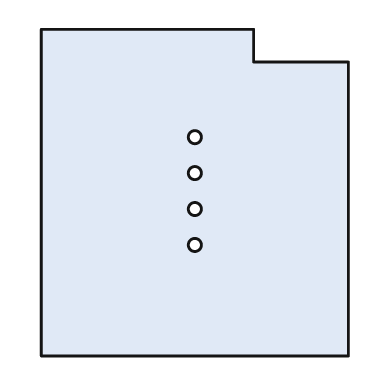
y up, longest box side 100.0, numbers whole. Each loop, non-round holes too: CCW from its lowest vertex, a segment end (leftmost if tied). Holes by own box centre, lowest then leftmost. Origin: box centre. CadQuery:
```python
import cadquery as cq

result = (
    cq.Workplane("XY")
    .moveTo(-47.0, -50.0)
    .lineTo(47.0, -50.0)
    .lineTo(47.0, 40.0)
    .lineTo(18.0, 40.0)
    .lineTo(18.0, 50.0)
    .lineTo(-47.0, 50.0)
    .close()
    .moveTo(0.0, -16.0)
    .circle(2.0)
    .moveTo(0.0, -5.0)
    .circle(2.0)
    .moveTo(0.0, 6.0)
    .circle(2.0)
    .moveTo(0.0, 17.0)
    .circle(2.0)
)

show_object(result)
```